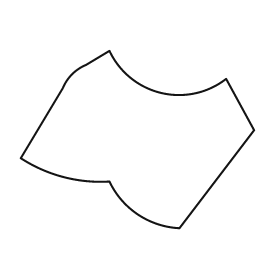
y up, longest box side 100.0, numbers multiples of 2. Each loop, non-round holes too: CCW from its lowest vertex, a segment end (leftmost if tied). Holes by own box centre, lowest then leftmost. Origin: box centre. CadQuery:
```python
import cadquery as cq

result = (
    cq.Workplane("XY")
    .moveTo(18.0, -38.0)
    .lineTo(50.0, 4.0)
    .lineTo(38.0, 26.0)
    .threePointArc((10.0, 20.0), (-12.0, 38.0))
    .lineTo(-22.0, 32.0)
    .threePointArc((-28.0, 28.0), (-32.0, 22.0))
    .lineTo(-50.0, -8.0)
    .threePointArc((-32.0, -16.0), (-12.0, -18.0))
    .threePointArc((0.0, -32.0), (18.0, -38.0))
    .close()
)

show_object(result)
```